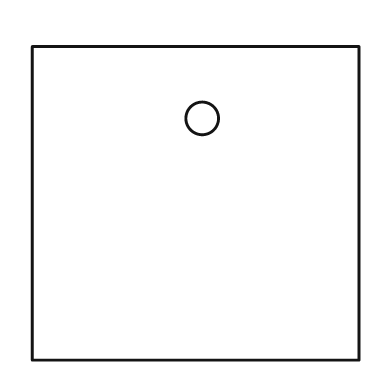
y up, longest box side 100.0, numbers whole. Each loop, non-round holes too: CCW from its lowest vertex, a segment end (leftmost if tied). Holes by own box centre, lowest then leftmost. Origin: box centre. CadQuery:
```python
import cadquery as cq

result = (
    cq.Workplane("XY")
    .moveTo(-50.0, -48.0)
    .lineTo(50.0, -48.0)
    .lineTo(50.0, 48.0)
    .lineTo(-50.0, 48.0)
    .close()
    .moveTo(2.0, 26.0)
    .circle(5.0)
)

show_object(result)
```